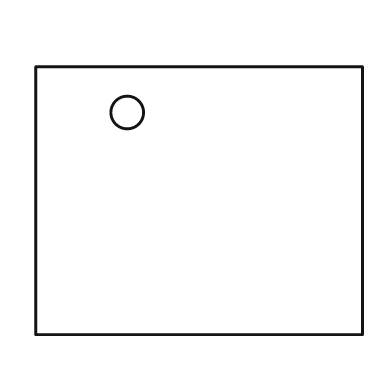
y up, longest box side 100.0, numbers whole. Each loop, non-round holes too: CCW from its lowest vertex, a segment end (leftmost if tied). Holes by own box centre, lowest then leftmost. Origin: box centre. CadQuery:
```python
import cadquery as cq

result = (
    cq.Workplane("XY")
    .moveTo(-50.0, -41.0)
    .lineTo(50.0, -41.0)
    .lineTo(50.0, 41.0)
    .lineTo(-50.0, 41.0)
    .close()
    .moveTo(-22.0, 27.0)
    .circle(5.0)
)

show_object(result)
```